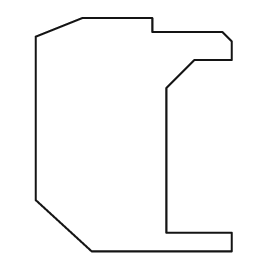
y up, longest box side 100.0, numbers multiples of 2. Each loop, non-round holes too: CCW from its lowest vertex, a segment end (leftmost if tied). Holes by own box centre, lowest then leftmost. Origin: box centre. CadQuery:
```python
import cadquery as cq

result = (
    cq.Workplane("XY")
    .moveTo(-18.0, -50.0)
    .lineTo(42.0, -50.0)
    .lineTo(42.0, -42.0)
    .lineTo(14.0, -42.0)
    .lineTo(14.0, 20.0)
    .lineTo(26.0, 32.0)
    .lineTo(42.0, 32.0)
    .lineTo(42.0, 40.0)
    .lineTo(38.0, 44.0)
    .lineTo(8.0, 44.0)
    .lineTo(8.0, 50.0)
    .lineTo(-22.0, 50.0)
    .lineTo(-42.0, 42.0)
    .lineTo(-42.0, -28.0)
    .close()
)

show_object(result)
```